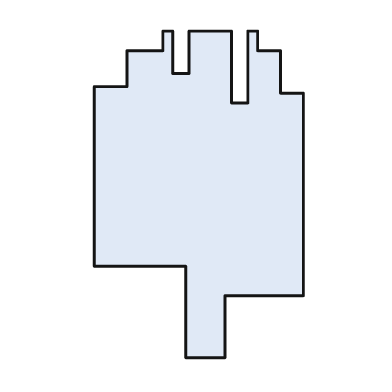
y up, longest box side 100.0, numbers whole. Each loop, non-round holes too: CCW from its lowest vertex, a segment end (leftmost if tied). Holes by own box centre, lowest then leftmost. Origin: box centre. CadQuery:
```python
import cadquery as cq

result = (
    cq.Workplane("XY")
    .moveTo(-4.0, -50.0)
    .lineTo(8.0, -50.0)
    .lineTo(8.0, -31.0)
    .lineTo(32.0, -31.0)
    .lineTo(32.0, 31.0)
    .lineTo(25.0, 31.0)
    .lineTo(25.0, 44.0)
    .lineTo(18.0, 44.0)
    .lineTo(18.0, 50.0)
    .lineTo(15.0, 50.0)
    .lineTo(15.0, 28.0)
    .lineTo(10.0, 28.0)
    .lineTo(10.0, 50.0)
    .lineTo(-3.0, 50.0)
    .lineTo(-3.0, 37.0)
    .lineTo(-8.0, 37.0)
    .lineTo(-8.0, 50.0)
    .lineTo(-11.0, 50.0)
    .lineTo(-11.0, 44.0)
    .lineTo(-22.0, 44.0)
    .lineTo(-22.0, 33.0)
    .lineTo(-32.0, 33.0)
    .lineTo(-32.0, -22.0)
    .lineTo(-4.0, -22.0)
    .close()
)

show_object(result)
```